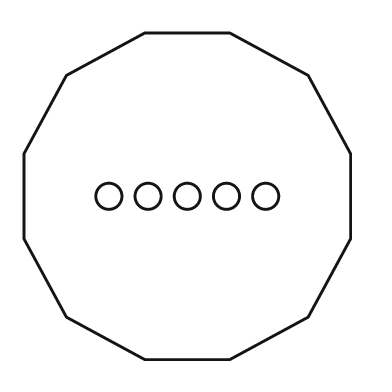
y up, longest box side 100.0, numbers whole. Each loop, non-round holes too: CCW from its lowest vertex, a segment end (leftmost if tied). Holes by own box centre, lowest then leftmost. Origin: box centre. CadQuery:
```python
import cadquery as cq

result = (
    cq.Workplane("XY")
    .moveTo(-13.0, -50.0)
    .lineTo(13.0, -50.0)
    .lineTo(37.0, -37.0)
    .lineTo(50.0, -13.0)
    .lineTo(50.0, 13.0)
    .lineTo(37.0, 37.0)
    .lineTo(13.0, 50.0)
    .lineTo(-13.0, 50.0)
    .lineTo(-37.0, 37.0)
    .lineTo(-50.0, 13.0)
    .lineTo(-50.0, -13.0)
    .lineTo(-37.0, -37.0)
    .close()
    .moveTo(-24.0, 0.0)
    .circle(4.0)
    .moveTo(-12.0, 0.0)
    .circle(4.0)
    .moveTo(0.0, 0.0)
    .circle(4.0)
    .moveTo(12.0, 0.0)
    .circle(4.0)
    .moveTo(24.0, 0.0)
    .circle(4.0)
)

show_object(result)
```